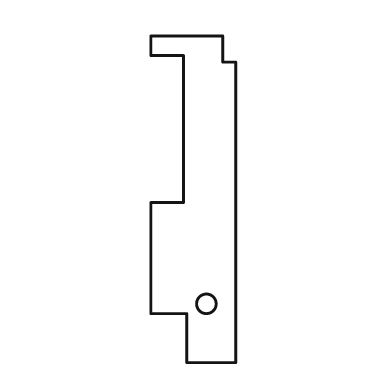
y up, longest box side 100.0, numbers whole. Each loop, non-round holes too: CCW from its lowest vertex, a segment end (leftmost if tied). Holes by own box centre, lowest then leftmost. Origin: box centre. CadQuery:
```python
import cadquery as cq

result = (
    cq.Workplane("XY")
    .moveTo(-2.0, -50.0)
    .lineTo(13.0, -50.0)
    .lineTo(13.0, 42.0)
    .lineTo(9.0, 42.0)
    .lineTo(9.0, 50.0)
    .lineTo(-13.0, 50.0)
    .lineTo(-13.0, 44.0)
    .lineTo(-3.0, 44.0)
    .lineTo(-3.0, -1.0)
    .lineTo(-13.0, -1.0)
    .lineTo(-13.0, -35.0)
    .lineTo(-2.0, -35.0)
    .close()
    .moveTo(4.0, -32.0)
    .circle(3.0)
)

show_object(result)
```